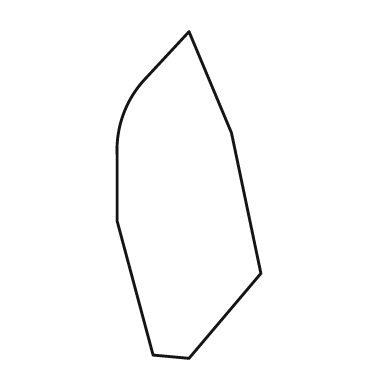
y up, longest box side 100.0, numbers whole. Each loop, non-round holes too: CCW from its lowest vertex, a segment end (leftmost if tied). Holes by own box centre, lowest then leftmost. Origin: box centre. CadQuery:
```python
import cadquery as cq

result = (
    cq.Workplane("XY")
    .moveTo(0.0, -50.0)
    .lineTo(22.0, -24.0)
    .lineTo(13.0, 19.0)
    .lineTo(0.0, 50.0)
    .lineTo(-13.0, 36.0)
    .threePointArc((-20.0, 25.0), (-22.0, 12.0))
    .lineTo(-22.0, -8.0)
    .lineTo(-11.0, -49.0)
    .close()
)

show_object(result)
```